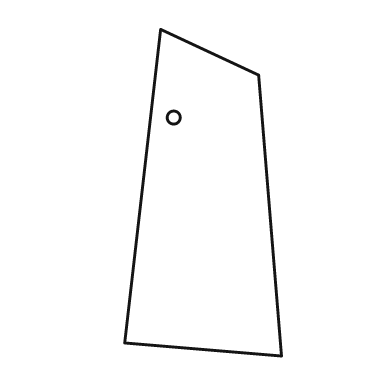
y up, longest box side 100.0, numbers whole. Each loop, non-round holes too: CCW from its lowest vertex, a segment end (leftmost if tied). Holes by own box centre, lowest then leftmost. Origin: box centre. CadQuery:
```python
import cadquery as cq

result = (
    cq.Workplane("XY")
    .moveTo(24.0, -50.0)
    .lineTo(17.0, 36.0)
    .lineTo(-13.0, 50.0)
    .lineTo(-24.0, -46.0)
    .close()
    .moveTo(-9.0, 23.0)
    .circle(2.0)
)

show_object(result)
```